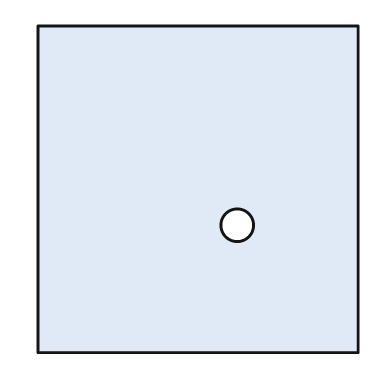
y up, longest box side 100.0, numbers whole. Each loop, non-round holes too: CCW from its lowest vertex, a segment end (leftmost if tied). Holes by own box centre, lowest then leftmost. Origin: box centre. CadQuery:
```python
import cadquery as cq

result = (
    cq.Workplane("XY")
    .moveTo(-49.0, -50.0)
    .lineTo(49.0, -50.0)
    .lineTo(49.0, 50.0)
    .lineTo(-49.0, 50.0)
    .close()
    .moveTo(12.0, -11.0)
    .circle(5.0)
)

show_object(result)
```